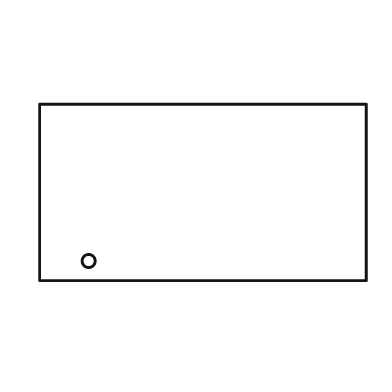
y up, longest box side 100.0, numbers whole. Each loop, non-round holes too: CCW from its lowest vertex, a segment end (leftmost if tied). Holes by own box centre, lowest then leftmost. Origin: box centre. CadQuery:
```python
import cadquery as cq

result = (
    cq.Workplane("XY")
    .moveTo(-50.0, -27.0)
    .lineTo(50.0, -27.0)
    .lineTo(50.0, 27.0)
    .lineTo(-50.0, 27.0)
    .close()
    .moveTo(-35.0, -21.0)
    .circle(2.0)
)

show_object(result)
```